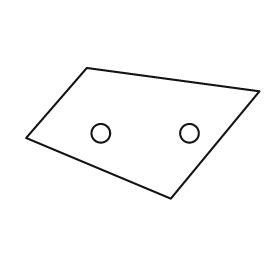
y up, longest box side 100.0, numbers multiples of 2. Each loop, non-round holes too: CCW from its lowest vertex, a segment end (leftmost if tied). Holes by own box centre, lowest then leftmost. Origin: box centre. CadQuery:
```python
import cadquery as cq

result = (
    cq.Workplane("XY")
    .moveTo(12.0, -28.0)
    .lineTo(50.0, 18.0)
    .lineTo(-24.0, 28.0)
    .lineTo(-50.0, -2.0)
    .close()
    .moveTo(-18.0, 0.0)
    .circle(4.0)
    .moveTo(20.0, 0.0)
    .circle(4.0)
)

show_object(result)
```